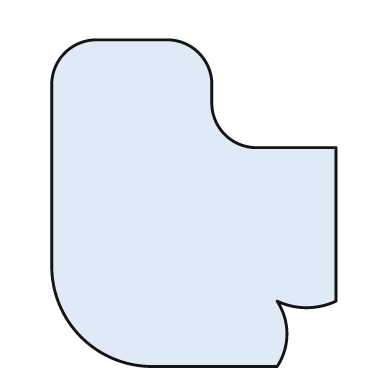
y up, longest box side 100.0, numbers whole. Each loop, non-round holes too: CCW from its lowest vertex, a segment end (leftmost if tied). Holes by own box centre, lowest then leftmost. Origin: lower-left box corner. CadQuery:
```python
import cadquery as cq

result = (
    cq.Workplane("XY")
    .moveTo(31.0, 0.0)
    .lineTo(69.0, 0.0)
    .threePointArc((72.0, 10.0), (69.0, 20.0))
    .threePointArc((78.0, 18.0), (87.0, 20.0))
    .lineTo(87.0, 67.0)
    .lineTo(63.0, 67.0)
    .threePointArc((53.0, 71.0), (49.0, 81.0))
    .lineTo(49.0, 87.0)
    .threePointArc((45.0, 96.0), (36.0, 100.0))
    .lineTo(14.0, 100.0)
    .threePointArc((4.0, 96.0), (0.0, 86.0))
    .lineTo(0.0, 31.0)
    .threePointArc((9.0, 9.0), (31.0, 0.0))
    .close()
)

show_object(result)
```